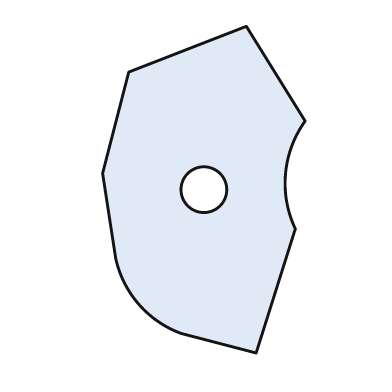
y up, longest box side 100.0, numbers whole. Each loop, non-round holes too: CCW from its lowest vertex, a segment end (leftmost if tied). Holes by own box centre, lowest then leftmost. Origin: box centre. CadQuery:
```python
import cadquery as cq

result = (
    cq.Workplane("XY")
    .moveTo(16.0, -50.0)
    .lineTo(28.0, -12.0)
    .threePointArc((25.0, 5.0), (31.0, 21.0))
    .lineTo(13.0, 50.0)
    .lineTo(-23.0, 36.0)
    .lineTo(-31.0, 5.0)
    .lineTo(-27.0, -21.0)
    .threePointArc((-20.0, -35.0), (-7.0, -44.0))
    .close()
    .moveTo(0.0, 0.0)
    .circle(7.0)
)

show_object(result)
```